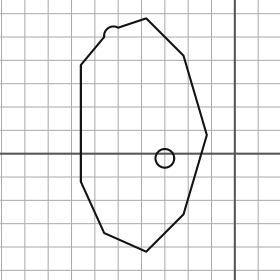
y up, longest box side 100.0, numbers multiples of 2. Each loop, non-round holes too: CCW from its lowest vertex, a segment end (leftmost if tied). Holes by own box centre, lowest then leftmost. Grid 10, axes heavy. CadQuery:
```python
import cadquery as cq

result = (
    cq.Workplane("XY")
    .moveTo(-38.0, -42.0)
    .lineTo(-22.0, -26.0)
    .lineTo(-12.0, 8.0)
    .lineTo(-22.0, 42.0)
    .lineTo(-38.0, 58.0)
    .lineTo(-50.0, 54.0)
    .threePointArc((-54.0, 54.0), (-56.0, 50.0))
    .lineTo(-66.0, 38.0)
    .lineTo(-66.0, -12.0)
    .lineTo(-56.0, -34.0)
    .close()
    .moveTo(-30.0, -2.0)
    .circle(4.0)
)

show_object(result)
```